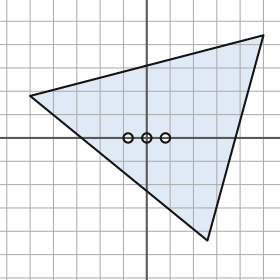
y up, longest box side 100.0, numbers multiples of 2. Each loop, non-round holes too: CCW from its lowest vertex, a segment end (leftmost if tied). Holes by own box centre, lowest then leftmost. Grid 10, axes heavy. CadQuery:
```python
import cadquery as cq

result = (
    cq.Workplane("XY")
    .moveTo(26.0, -44.0)
    .lineTo(50.0, 44.0)
    .lineTo(-50.0, 18.0)
    .close()
    .moveTo(-8.0, 0.0)
    .circle(2.0)
    .moveTo(0.0, 0.0)
    .circle(2.0)
    .moveTo(8.0, 0.0)
    .circle(2.0)
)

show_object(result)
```